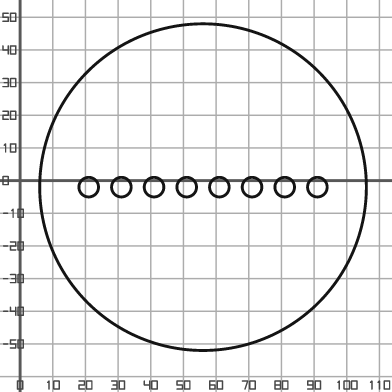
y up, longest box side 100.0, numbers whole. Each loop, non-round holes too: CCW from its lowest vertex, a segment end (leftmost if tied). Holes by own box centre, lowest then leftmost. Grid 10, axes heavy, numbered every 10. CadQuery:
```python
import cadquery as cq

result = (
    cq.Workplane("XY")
    .moveTo(56.0, -2.0)
    .circle(50.0)
    .moveTo(21.0, -2.0)
    .circle(3.0)
    .moveTo(31.0, -2.0)
    .circle(3.0)
    .moveTo(41.0, -2.0)
    .circle(3.0)
    .moveTo(51.0, -2.0)
    .circle(3.0)
    .moveTo(61.0, -2.0)
    .circle(3.0)
    .moveTo(71.0, -2.0)
    .circle(3.0)
    .moveTo(81.0, -2.0)
    .circle(3.0)
    .moveTo(91.0, -2.0)
    .circle(3.0)
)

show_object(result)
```